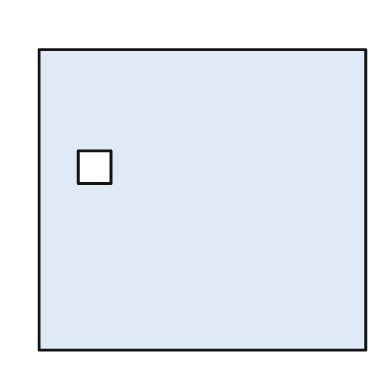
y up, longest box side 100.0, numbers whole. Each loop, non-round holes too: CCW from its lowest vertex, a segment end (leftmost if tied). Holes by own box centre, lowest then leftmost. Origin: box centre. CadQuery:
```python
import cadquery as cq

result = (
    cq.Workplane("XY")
    .moveTo(-50.0, -46.0)
    .lineTo(50.0, -46.0)
    .lineTo(50.0, 46.0)
    .lineTo(-50.0, 46.0)
    .close()
    .moveTo(-38.0, 5.0)
    .lineTo(-28.0, 5.0)
    .lineTo(-28.0, 15.0)
    .lineTo(-38.0, 15.0)
    .close()
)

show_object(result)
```